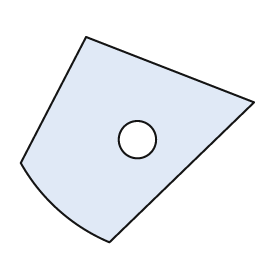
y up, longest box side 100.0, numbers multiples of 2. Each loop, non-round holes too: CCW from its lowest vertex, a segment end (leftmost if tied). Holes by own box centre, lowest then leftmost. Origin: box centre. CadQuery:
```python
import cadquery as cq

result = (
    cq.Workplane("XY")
    .moveTo(-12.0, -44.0)
    .lineTo(50.0, 16.0)
    .lineTo(-22.0, 44.0)
    .lineTo(-50.0, -10.0)
    .threePointArc((-34.0, -30.0), (-12.0, -44.0))
    .close()
    .moveTo(0.0, 0.0)
    .circle(8.0)
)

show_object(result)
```